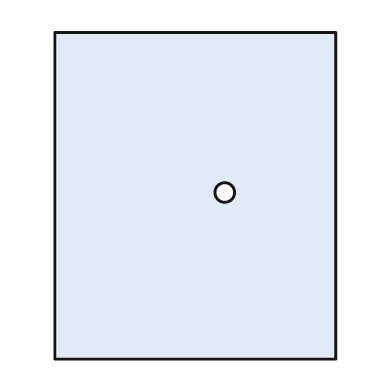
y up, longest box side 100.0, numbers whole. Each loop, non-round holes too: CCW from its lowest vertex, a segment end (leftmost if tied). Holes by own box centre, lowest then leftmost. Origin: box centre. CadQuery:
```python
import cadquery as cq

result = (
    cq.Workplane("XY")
    .moveTo(-43.0, -50.0)
    .lineTo(43.0, -50.0)
    .lineTo(43.0, 50.0)
    .lineTo(-43.0, 50.0)
    .close()
    .moveTo(9.0, 1.0)
    .circle(3.0)
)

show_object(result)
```